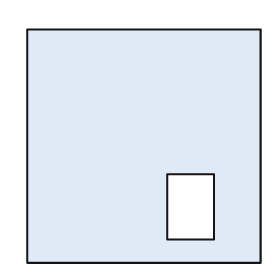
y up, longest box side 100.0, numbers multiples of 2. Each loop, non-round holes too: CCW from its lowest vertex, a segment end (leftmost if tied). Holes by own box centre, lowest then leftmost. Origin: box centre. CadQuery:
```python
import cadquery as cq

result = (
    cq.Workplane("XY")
    .moveTo(-50.0, -50.0)
    .lineTo(50.0, -50.0)
    .lineTo(50.0, 50.0)
    .lineTo(-50.0, 50.0)
    .close()
    .moveTo(10.0, -40.0)
    .lineTo(30.0, -40.0)
    .lineTo(30.0, -12.0)
    .lineTo(10.0, -12.0)
    .close()
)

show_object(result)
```